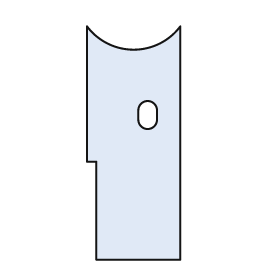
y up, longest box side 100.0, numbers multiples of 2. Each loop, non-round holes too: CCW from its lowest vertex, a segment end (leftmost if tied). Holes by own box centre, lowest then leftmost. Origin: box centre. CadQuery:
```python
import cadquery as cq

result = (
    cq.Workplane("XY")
    .moveTo(-16.0, -50.0)
    .lineTo(20.0, -50.0)
    .lineTo(20.0, 50.0)
    .threePointArc((0.0, 40.0), (-20.0, 50.0))
    .lineTo(-20.0, -8.0)
    .lineTo(-16.0, -8.0)
    .close()
    .moveTo(2.0, 10.0)
    .threePointArc((6.0, 6.0), (10.0, 10.0))
    .lineTo(10.0, 14.0)
    .threePointArc((6.0, 18.0), (2.0, 14.0))
    .close()
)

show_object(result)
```